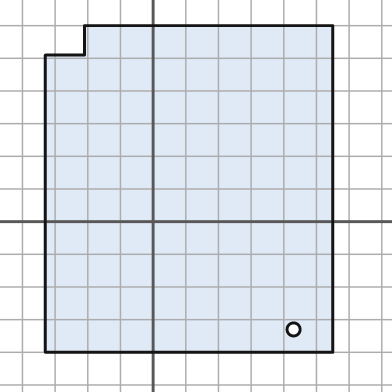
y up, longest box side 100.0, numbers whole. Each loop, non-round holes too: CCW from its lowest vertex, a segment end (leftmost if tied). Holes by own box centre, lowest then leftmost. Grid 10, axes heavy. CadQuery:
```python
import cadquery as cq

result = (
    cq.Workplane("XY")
    .moveTo(-33.0, -40.0)
    .lineTo(55.0, -40.0)
    .lineTo(55.0, 60.0)
    .lineTo(-21.0, 60.0)
    .lineTo(-21.0, 51.0)
    .lineTo(-33.0, 51.0)
    .close()
    .moveTo(43.0, -33.0)
    .circle(2.0)
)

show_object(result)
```